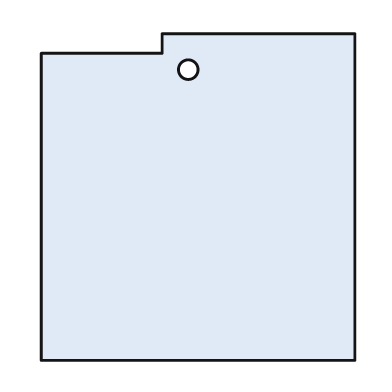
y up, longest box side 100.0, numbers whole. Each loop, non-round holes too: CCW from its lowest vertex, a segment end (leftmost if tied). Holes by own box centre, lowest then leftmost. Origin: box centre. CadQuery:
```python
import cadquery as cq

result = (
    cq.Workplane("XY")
    .moveTo(-48.0, -50.0)
    .lineTo(48.0, -50.0)
    .lineTo(48.0, 50.0)
    .lineTo(-11.0, 50.0)
    .lineTo(-11.0, 44.0)
    .lineTo(-48.0, 44.0)
    .close()
    .moveTo(-3.0, 39.0)
    .circle(3.0)
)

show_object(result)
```